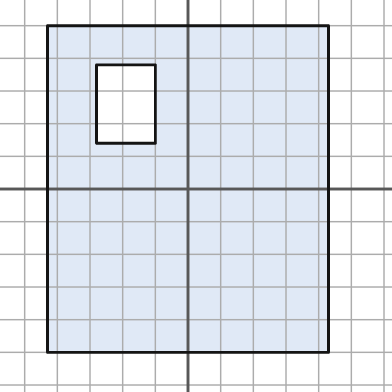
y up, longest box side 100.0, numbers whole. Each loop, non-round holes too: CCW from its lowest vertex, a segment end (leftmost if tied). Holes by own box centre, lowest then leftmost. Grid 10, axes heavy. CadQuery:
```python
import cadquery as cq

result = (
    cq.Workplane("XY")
    .moveTo(-43.0, -50.0)
    .lineTo(43.0, -50.0)
    .lineTo(43.0, 50.0)
    .lineTo(-43.0, 50.0)
    .close()
    .moveTo(-28.0, 14.0)
    .lineTo(-10.0, 14.0)
    .lineTo(-10.0, 38.0)
    .lineTo(-28.0, 38.0)
    .close()
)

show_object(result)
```